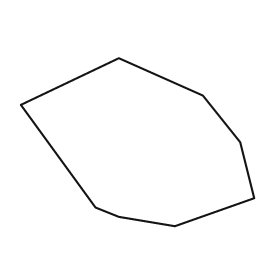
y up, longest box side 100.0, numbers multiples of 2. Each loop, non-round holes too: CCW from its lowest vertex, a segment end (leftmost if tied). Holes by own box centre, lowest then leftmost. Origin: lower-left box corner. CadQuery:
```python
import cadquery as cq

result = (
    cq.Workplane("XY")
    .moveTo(66.0, 0.0)
    .lineTo(100.0, 12.0)
    .lineTo(94.0, 36.0)
    .lineTo(78.0, 56.0)
    .lineTo(42.0, 72.0)
    .lineTo(0.0, 52.0)
    .lineTo(32.0, 8.0)
    .lineTo(42.0, 4.0)
    .close()
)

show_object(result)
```